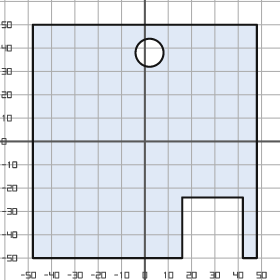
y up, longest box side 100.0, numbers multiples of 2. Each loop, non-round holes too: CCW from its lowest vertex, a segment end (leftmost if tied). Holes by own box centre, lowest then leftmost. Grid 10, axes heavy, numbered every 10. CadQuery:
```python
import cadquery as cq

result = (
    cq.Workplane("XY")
    .moveTo(-48.0, -50.0)
    .lineTo(16.0, -50.0)
    .lineTo(16.0, -24.0)
    .lineTo(42.0, -24.0)
    .lineTo(42.0, -50.0)
    .lineTo(48.0, -50.0)
    .lineTo(48.0, 50.0)
    .lineTo(-48.0, 50.0)
    .close()
    .moveTo(2.0, 38.0)
    .circle(6.0)
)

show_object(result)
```